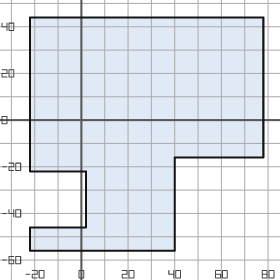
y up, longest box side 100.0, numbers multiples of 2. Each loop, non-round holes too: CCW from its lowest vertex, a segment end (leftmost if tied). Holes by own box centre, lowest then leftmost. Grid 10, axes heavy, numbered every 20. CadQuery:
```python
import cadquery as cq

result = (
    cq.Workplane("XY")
    .moveTo(-22.0, -56.0)
    .lineTo(40.0, -56.0)
    .lineTo(40.0, -16.0)
    .lineTo(78.0, -16.0)
    .lineTo(78.0, 44.0)
    .lineTo(-22.0, 44.0)
    .lineTo(-22.0, -22.0)
    .lineTo(2.0, -22.0)
    .lineTo(2.0, -46.0)
    .lineTo(-22.0, -46.0)
    .close()
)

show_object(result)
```